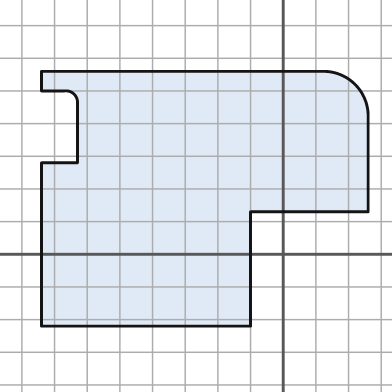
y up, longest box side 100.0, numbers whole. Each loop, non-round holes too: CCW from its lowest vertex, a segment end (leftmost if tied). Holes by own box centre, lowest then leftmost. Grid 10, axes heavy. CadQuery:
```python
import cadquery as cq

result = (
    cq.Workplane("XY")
    .moveTo(-74.0, -22.0)
    .lineTo(-10.0, -22.0)
    .lineTo(-10.0, 13.0)
    .lineTo(26.0, 13.0)
    .lineTo(26.0, 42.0)
    .threePointArc((22.0, 52.0), (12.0, 56.0))
    .lineTo(-74.0, 56.0)
    .lineTo(-74.0, 50.0)
    .lineTo(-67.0, 50.0)
    .threePointArc((-64.0, 49.0), (-63.0, 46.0))
    .lineTo(-63.0, 28.0)
    .lineTo(-74.0, 28.0)
    .close()
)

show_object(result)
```